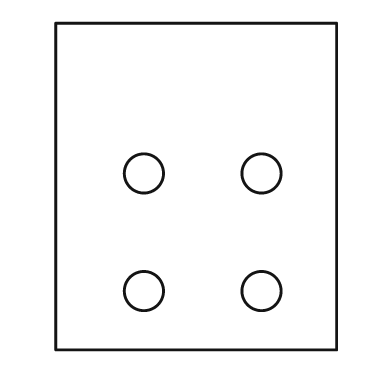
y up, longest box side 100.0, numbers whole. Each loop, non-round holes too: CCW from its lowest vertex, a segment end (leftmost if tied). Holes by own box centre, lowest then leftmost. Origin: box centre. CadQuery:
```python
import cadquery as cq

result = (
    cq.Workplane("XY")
    .moveTo(-43.0, -50.0)
    .lineTo(43.0, -50.0)
    .lineTo(43.0, 50.0)
    .lineTo(-43.0, 50.0)
    .close()
    .moveTo(-16.0, -32.0)
    .circle(6.0)
    .moveTo(20.0, -32.0)
    .circle(6.0)
    .moveTo(-16.0, 4.0)
    .circle(6.0)
    .moveTo(20.0, 4.0)
    .circle(6.0)
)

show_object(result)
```